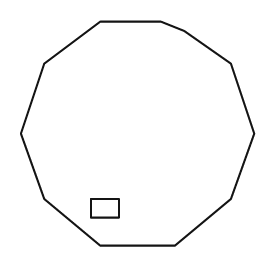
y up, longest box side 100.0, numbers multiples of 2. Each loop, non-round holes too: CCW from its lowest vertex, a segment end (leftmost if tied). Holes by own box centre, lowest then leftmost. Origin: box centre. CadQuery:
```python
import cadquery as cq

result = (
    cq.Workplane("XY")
    .moveTo(-16.0, -48.0)
    .lineTo(16.0, -48.0)
    .lineTo(40.0, -28.0)
    .lineTo(50.0, 0.0)
    .lineTo(40.0, 30.0)
    .lineTo(20.0, 44.0)
    .lineTo(10.0, 48.0)
    .lineTo(-16.0, 48.0)
    .lineTo(-40.0, 30.0)
    .lineTo(-50.0, 0.0)
    .lineTo(-40.0, -28.0)
    .close()
    .moveTo(-20.0, -36.0)
    .lineTo(-8.0, -36.0)
    .lineTo(-8.0, -28.0)
    .lineTo(-20.0, -28.0)
    .close()
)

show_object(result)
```